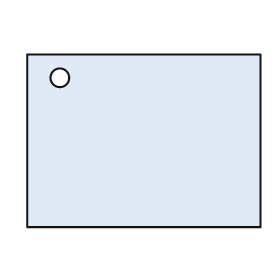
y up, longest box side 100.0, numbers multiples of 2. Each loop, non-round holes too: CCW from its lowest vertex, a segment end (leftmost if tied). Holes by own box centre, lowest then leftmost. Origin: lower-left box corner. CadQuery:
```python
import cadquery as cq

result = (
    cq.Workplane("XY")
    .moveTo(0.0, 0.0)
    .lineTo(100.0, 0.0)
    .lineTo(100.0, 74.0)
    .lineTo(0.0, 74.0)
    .close()
    .moveTo(14.0, 64.0)
    .circle(4.0)
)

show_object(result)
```